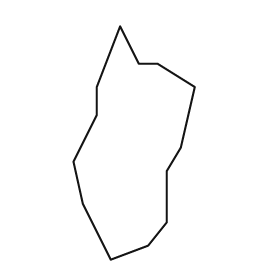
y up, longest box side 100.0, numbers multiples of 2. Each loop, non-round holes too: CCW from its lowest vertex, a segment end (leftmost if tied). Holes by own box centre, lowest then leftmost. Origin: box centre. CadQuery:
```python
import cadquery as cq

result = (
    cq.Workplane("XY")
    .moveTo(-10.0, -50.0)
    .lineTo(6.0, -44.0)
    .lineTo(14.0, -34.0)
    .lineTo(14.0, -12.0)
    .lineTo(20.0, -2.0)
    .lineTo(26.0, 24.0)
    .lineTo(10.0, 34.0)
    .lineTo(2.0, 34.0)
    .lineTo(-6.0, 50.0)
    .lineTo(-16.0, 24.0)
    .lineTo(-16.0, 12.0)
    .lineTo(-26.0, -8.0)
    .lineTo(-22.0, -26.0)
    .close()
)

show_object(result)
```